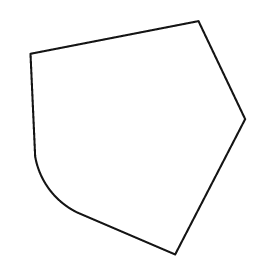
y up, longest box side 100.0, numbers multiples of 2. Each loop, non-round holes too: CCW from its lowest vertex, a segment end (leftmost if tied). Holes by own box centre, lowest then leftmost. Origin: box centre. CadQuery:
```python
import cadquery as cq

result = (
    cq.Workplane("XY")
    .moveTo(16.0, -50.0)
    .lineTo(46.0, 8.0)
    .lineTo(26.0, 50.0)
    .lineTo(-46.0, 36.0)
    .lineTo(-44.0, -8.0)
    .threePointArc((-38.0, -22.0), (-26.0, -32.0))
    .close()
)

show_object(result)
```